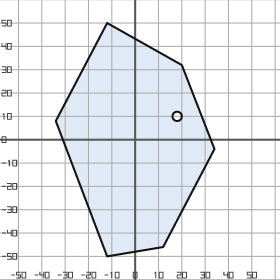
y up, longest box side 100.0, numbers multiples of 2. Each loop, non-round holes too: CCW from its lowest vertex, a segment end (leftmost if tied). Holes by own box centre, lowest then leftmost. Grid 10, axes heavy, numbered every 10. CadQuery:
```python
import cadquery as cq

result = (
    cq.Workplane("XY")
    .moveTo(-12.0, -50.0)
    .lineTo(12.0, -46.0)
    .lineTo(34.0, -4.0)
    .lineTo(20.0, 32.0)
    .lineTo(-12.0, 50.0)
    .lineTo(-34.0, 8.0)
    .close()
    .moveTo(18.0, 10.0)
    .circle(2.0)
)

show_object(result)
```